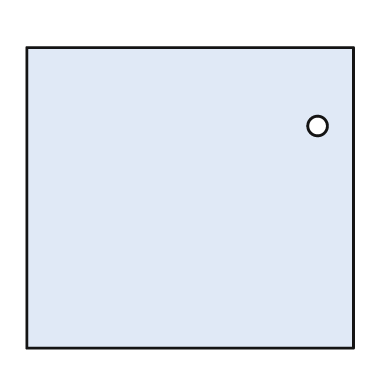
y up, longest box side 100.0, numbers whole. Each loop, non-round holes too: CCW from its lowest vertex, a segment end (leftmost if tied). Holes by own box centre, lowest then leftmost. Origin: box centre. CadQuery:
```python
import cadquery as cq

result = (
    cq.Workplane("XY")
    .moveTo(-50.0, -46.0)
    .lineTo(50.0, -46.0)
    .lineTo(50.0, 46.0)
    .lineTo(-50.0, 46.0)
    .close()
    .moveTo(39.0, 22.0)
    .circle(3.0)
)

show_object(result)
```